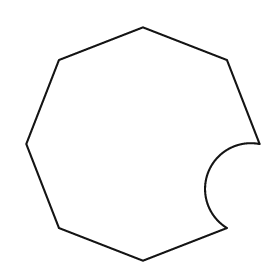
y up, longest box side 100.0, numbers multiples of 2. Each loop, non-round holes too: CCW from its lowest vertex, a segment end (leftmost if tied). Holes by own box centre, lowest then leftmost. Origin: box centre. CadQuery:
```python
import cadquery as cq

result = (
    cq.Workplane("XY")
    .moveTo(0.0, -50.0)
    .lineTo(36.0, -36.0)
    .threePointArc((28.0, -12.0), (50.0, 0.0))
    .lineTo(36.0, 36.0)
    .lineTo(0.0, 50.0)
    .lineTo(-36.0, 36.0)
    .lineTo(-50.0, 0.0)
    .lineTo(-36.0, -36.0)
    .close()
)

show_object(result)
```